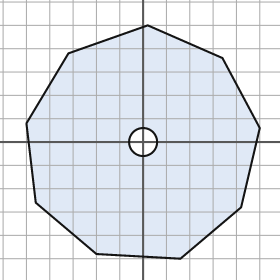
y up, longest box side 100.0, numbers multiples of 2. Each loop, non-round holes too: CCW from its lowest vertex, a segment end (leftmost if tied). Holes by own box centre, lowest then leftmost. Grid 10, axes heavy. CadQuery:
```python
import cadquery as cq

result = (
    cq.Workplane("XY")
    .moveTo(16.0, -50.0)
    .lineTo(42.0, -28.0)
    .lineTo(50.0, 6.0)
    .lineTo(34.0, 36.0)
    .lineTo(2.0, 50.0)
    .lineTo(-32.0, 38.0)
    .lineTo(-50.0, 8.0)
    .lineTo(-46.0, -26.0)
    .lineTo(-20.0, -48.0)
    .close()
    .moveTo(0.0, 0.0)
    .circle(6.0)
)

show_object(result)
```